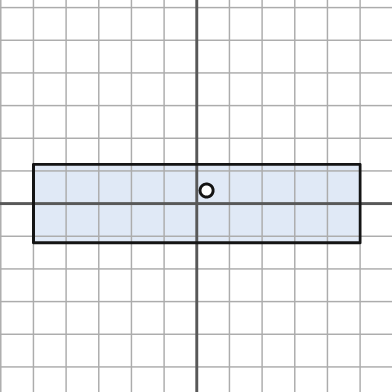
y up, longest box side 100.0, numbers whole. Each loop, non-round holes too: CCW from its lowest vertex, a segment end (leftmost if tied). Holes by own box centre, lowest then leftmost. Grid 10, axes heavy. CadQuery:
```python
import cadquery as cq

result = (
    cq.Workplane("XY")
    .moveTo(-50.0, -12.0)
    .lineTo(50.0, -12.0)
    .lineTo(50.0, 12.0)
    .lineTo(-50.0, 12.0)
    .close()
    .moveTo(3.0, 4.0)
    .circle(2.0)
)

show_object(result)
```